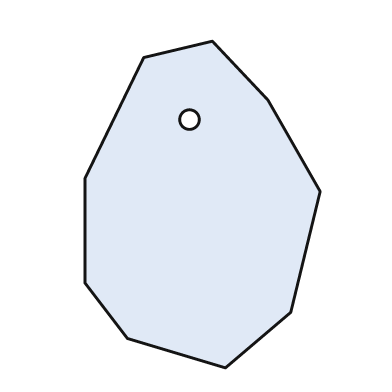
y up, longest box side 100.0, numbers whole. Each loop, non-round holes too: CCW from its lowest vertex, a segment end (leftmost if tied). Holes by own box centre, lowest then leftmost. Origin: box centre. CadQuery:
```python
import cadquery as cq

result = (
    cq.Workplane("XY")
    .moveTo(7.0, -50.0)
    .lineTo(27.0, -33.0)
    .lineTo(36.0, 4.0)
    .lineTo(20.0, 32.0)
    .lineTo(3.0, 50.0)
    .lineTo(-18.0, 45.0)
    .lineTo(-36.0, 8.0)
    .lineTo(-36.0, -24.0)
    .lineTo(-23.0, -41.0)
    .close()
    .moveTo(-4.0, 26.0)
    .circle(3.0)
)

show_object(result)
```